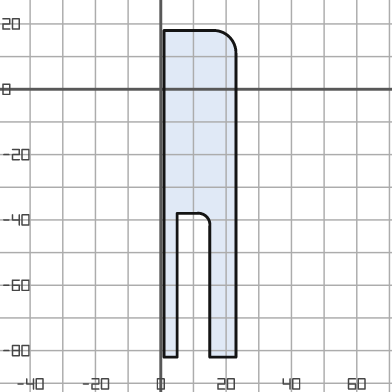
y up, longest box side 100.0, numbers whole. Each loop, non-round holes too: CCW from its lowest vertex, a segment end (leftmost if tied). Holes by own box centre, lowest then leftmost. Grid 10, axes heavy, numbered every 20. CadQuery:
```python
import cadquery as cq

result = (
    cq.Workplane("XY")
    .moveTo(1.0, -82.0)
    .lineTo(5.0, -82.0)
    .lineTo(5.0, -38.0)
    .lineTo(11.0, -38.0)
    .threePointArc((14.0, -39.0), (15.0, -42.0))
    .lineTo(15.0, -82.0)
    .lineTo(23.0, -82.0)
    .lineTo(23.0, 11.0)
    .threePointArc((21.0, 16.0), (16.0, 18.0))
    .lineTo(1.0, 18.0)
    .close()
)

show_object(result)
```